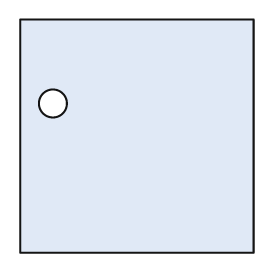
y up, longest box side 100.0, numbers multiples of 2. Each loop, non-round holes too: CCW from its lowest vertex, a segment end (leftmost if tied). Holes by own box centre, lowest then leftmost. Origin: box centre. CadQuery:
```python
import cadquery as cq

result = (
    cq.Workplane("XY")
    .moveTo(-50.0, -50.0)
    .lineTo(50.0, -50.0)
    .lineTo(50.0, 50.0)
    .lineTo(-50.0, 50.0)
    .close()
    .moveTo(-36.0, 14.0)
    .circle(6.0)
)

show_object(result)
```